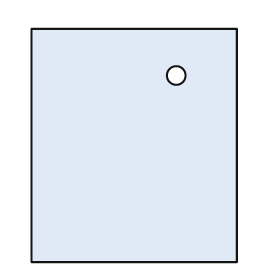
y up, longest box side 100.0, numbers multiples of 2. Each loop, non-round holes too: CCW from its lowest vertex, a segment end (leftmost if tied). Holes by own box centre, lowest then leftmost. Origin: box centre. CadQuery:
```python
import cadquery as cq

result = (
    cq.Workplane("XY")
    .moveTo(-44.0, -50.0)
    .lineTo(44.0, -50.0)
    .lineTo(44.0, 50.0)
    .lineTo(-44.0, 50.0)
    .close()
    .moveTo(18.0, 30.0)
    .circle(4.0)
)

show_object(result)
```